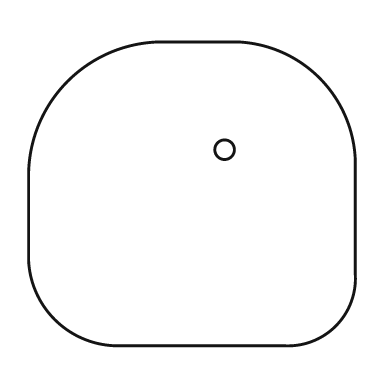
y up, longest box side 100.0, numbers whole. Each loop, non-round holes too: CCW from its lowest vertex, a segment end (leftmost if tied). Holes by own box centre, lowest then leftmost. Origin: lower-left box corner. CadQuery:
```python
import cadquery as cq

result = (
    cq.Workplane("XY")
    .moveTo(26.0, 0.0)
    .lineTo(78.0, 0.0)
    .threePointArc((94.0, 6.0), (100.0, 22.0))
    .lineTo(100.0, 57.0)
    .threePointArc((89.0, 82.0), (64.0, 93.0))
    .lineTo(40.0, 93.0)
    .threePointArc((12.0, 81.0), (0.0, 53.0))
    .lineTo(0.0, 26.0)
    .threePointArc((8.0, 8.0), (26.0, 0.0))
    .close()
    .moveTo(60.0, 60.0)
    .circle(3.0)
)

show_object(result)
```